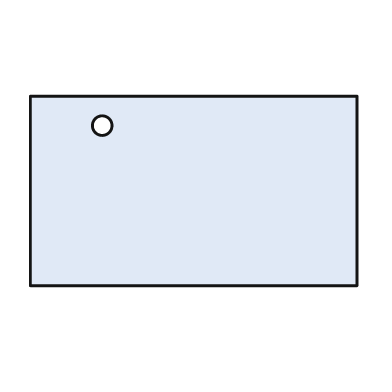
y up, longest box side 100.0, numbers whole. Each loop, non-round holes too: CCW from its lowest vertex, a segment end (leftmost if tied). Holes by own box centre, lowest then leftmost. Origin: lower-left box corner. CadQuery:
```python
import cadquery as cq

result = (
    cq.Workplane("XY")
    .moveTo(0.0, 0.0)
    .lineTo(100.0, 0.0)
    .lineTo(100.0, 58.0)
    .lineTo(0.0, 58.0)
    .close()
    .moveTo(22.0, 49.0)
    .circle(3.0)
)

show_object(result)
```